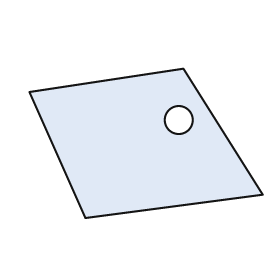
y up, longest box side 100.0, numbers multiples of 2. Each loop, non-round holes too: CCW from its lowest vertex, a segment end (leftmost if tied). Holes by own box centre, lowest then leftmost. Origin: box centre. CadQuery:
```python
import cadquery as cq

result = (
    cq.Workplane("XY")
    .moveTo(-26.0, -32.0)
    .lineTo(50.0, -22.0)
    .lineTo(16.0, 32.0)
    .lineTo(-50.0, 22.0)
    .close()
    .moveTo(14.0, 10.0)
    .circle(6.0)
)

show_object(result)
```